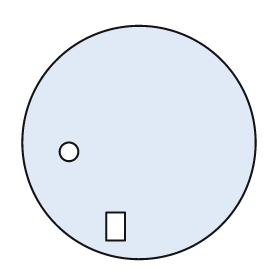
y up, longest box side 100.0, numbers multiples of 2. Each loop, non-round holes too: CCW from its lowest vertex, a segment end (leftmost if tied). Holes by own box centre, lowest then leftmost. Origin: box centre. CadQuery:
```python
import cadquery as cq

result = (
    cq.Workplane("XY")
    .moveTo(0.0, 0.0)
    .circle(50.0)
    .moveTo(-14.0, -42.0)
    .lineTo(-6.0, -42.0)
    .lineTo(-6.0, -30.0)
    .lineTo(-14.0, -30.0)
    .close()
    .moveTo(-30.0, -4.0)
    .circle(4.0)
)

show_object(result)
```